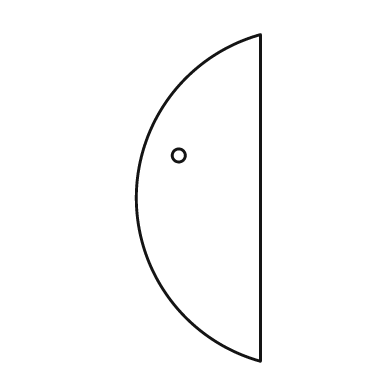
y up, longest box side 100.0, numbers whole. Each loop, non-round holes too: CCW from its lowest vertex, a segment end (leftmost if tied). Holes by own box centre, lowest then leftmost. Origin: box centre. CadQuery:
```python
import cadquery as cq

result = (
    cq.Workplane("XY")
    .moveTo(19.0, -50.0)
    .lineTo(19.0, 50.0)
    .threePointArc((-19.0, 0.0), (19.0, -50.0))
    .close()
    .moveTo(-6.0, 13.0)
    .circle(2.0)
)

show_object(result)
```